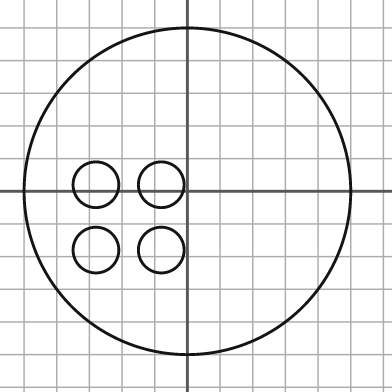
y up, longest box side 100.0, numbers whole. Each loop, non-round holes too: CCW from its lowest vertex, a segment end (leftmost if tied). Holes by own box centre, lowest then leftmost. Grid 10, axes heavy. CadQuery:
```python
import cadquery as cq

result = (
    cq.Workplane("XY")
    .moveTo(0.0, 0.0)
    .circle(50.0)
    .moveTo(-28.0, -18.0)
    .circle(7.0)
    .moveTo(-8.0, -18.0)
    .circle(7.0)
    .moveTo(-28.0, 2.0)
    .circle(7.0)
    .moveTo(-8.0, 2.0)
    .circle(7.0)
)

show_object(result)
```